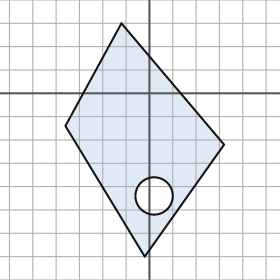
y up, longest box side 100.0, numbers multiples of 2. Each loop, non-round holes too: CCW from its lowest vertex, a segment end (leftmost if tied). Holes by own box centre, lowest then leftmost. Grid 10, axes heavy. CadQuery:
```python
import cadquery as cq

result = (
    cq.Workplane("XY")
    .moveTo(-2.0, -70.0)
    .lineTo(32.0, -22.0)
    .lineTo(-12.0, 30.0)
    .lineTo(-36.0, -14.0)
    .close()
    .moveTo(2.0, -44.0)
    .circle(8.0)
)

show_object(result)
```